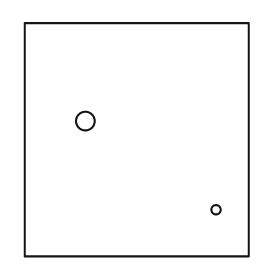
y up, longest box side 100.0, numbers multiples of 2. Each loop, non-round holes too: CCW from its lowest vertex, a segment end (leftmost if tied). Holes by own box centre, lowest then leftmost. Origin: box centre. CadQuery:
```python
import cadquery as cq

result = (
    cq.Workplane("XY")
    .moveTo(-48.0, -50.0)
    .lineTo(48.0, -50.0)
    .lineTo(48.0, 50.0)
    .lineTo(-48.0, 50.0)
    .close()
    .moveTo(34.0, -30.0)
    .circle(2.0)
    .moveTo(-22.0, 8.0)
    .circle(4.0)
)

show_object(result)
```